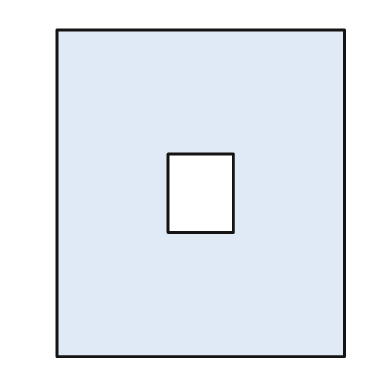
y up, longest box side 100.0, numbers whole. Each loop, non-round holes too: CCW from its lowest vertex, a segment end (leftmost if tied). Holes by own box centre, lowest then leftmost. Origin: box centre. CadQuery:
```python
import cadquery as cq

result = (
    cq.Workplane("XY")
    .moveTo(-44.0, -50.0)
    .lineTo(44.0, -50.0)
    .lineTo(44.0, 50.0)
    .lineTo(-44.0, 50.0)
    .close()
    .moveTo(-10.0, -12.0)
    .lineTo(10.0, -12.0)
    .lineTo(10.0, 12.0)
    .lineTo(-10.0, 12.0)
    .close()
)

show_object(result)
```